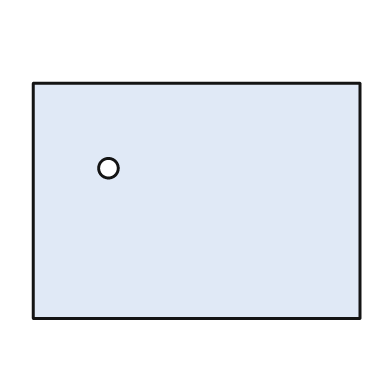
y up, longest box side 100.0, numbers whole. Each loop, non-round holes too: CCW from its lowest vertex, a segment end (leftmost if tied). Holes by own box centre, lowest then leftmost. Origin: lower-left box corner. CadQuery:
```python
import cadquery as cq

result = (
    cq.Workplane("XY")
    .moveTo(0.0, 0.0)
    .lineTo(100.0, 0.0)
    .lineTo(100.0, 72.0)
    .lineTo(0.0, 72.0)
    .close()
    .moveTo(23.0, 46.0)
    .circle(3.0)
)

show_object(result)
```